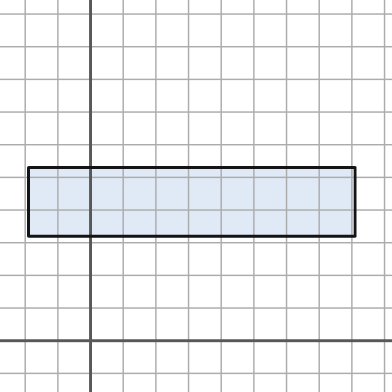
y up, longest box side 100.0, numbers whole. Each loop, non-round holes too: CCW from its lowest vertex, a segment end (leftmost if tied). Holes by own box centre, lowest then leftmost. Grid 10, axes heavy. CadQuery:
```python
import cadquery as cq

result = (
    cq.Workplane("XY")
    .moveTo(-19.0, 32.0)
    .lineTo(81.0, 32.0)
    .lineTo(81.0, 53.0)
    .lineTo(-19.0, 53.0)
    .close()
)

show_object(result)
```